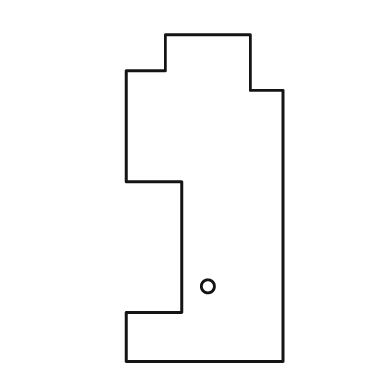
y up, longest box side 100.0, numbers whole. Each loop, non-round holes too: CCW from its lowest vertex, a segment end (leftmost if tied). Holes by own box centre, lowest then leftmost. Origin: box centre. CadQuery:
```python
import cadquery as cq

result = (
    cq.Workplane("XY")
    .moveTo(-24.0, -50.0)
    .lineTo(24.0, -50.0)
    .lineTo(24.0, 33.0)
    .lineTo(14.0, 33.0)
    .lineTo(14.0, 50.0)
    .lineTo(-12.0, 50.0)
    .lineTo(-12.0, 39.0)
    .lineTo(-24.0, 39.0)
    .lineTo(-24.0, 5.0)
    .lineTo(-7.0, 5.0)
    .lineTo(-7.0, -35.0)
    .lineTo(-24.0, -35.0)
    .close()
    .moveTo(1.0, -27.0)
    .circle(2.0)
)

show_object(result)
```